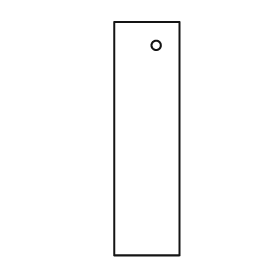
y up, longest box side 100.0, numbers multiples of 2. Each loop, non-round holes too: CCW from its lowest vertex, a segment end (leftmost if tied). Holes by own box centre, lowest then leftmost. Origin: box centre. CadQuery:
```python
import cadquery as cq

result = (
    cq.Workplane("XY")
    .moveTo(-14.0, -50.0)
    .lineTo(14.0, -50.0)
    .lineTo(14.0, 50.0)
    .lineTo(-14.0, 50.0)
    .close()
    .moveTo(4.0, 40.0)
    .circle(2.0)
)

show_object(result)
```